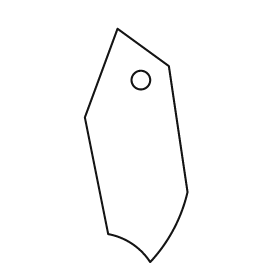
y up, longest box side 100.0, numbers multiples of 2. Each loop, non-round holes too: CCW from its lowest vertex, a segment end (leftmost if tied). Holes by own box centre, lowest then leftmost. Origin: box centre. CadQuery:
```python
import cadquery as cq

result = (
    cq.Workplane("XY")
    .moveTo(6.0, -50.0)
    .threePointArc((16.0, -36.0), (22.0, -20.0))
    .lineTo(14.0, 34.0)
    .lineTo(-8.0, 50.0)
    .lineTo(-22.0, 12.0)
    .lineTo(-12.0, -38.0)
    .threePointArc((-2.0, -42.0), (6.0, -50.0))
    .close()
    .moveTo(2.0, 28.0)
    .circle(4.0)
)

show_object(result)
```